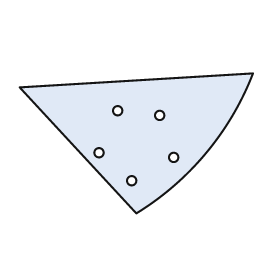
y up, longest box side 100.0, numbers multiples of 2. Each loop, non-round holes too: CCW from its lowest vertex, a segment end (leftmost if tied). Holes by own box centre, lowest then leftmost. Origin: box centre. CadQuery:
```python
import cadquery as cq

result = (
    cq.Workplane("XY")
    .moveTo(0.0, -30.0)
    .threePointArc((30.0, -4.0), (50.0, 30.0))
    .lineTo(-50.0, 24.0)
    .close()
    .moveTo(-2.0, -16.0)
    .circle(2.0)
    .moveTo(16.0, -6.0)
    .circle(2.0)
    .moveTo(-16.0, -4.0)
    .circle(2.0)
    .moveTo(10.0, 12.0)
    .circle(2.0)
    .moveTo(-8.0, 14.0)
    .circle(2.0)
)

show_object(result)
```